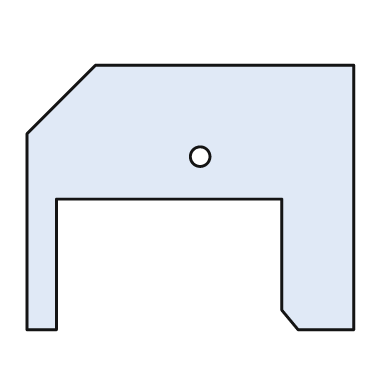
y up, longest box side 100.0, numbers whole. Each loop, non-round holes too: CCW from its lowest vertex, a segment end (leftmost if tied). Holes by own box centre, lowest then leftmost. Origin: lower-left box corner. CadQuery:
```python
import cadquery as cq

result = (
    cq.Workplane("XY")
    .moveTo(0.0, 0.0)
    .lineTo(9.0, 0.0)
    .lineTo(9.0, 40.0)
    .lineTo(78.0, 40.0)
    .lineTo(78.0, 6.0)
    .lineTo(83.0, 0.0)
    .lineTo(100.0, 0.0)
    .lineTo(100.0, 81.0)
    .lineTo(21.0, 81.0)
    .lineTo(0.0, 60.0)
    .close()
    .moveTo(53.0, 53.0)
    .circle(3.0)
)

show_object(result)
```